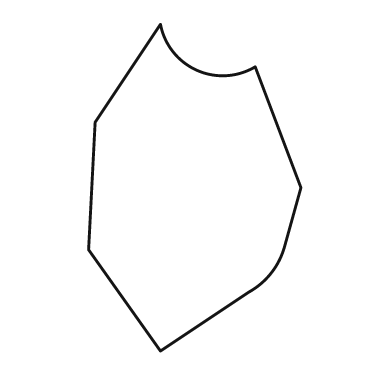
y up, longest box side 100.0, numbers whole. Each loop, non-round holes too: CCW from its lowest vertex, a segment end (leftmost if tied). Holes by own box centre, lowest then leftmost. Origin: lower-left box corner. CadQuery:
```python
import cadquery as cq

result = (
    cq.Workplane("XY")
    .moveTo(22.0, 0.0)
    .lineTo(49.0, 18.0)
    .threePointArc((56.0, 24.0), (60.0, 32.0))
    .lineTo(65.0, 50.0)
    .lineTo(51.0, 87.0)
    .threePointArc((33.0, 86.0), (22.0, 100.0))
    .lineTo(2.0, 70.0)
    .lineTo(0.0, 31.0)
    .close()
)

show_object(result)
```